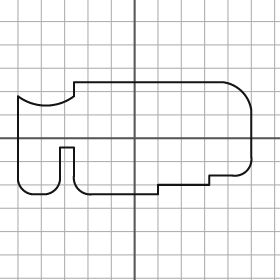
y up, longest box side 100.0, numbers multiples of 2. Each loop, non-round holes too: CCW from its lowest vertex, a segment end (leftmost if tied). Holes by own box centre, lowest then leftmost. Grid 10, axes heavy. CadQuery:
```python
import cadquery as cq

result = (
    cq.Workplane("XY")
    .moveTo(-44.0, -24.0)
    .lineTo(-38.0, -24.0)
    .threePointArc((-34.0, -22.0), (-32.0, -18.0))
    .lineTo(-32.0, -4.0)
    .lineTo(-26.0, -4.0)
    .lineTo(-26.0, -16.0)
    .threePointArc((-24.0, -22.0), (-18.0, -24.0))
    .lineTo(10.0, -24.0)
    .lineTo(10.0, -20.0)
    .lineTo(32.0, -20.0)
    .lineTo(32.0, -16.0)
    .lineTo(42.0, -16.0)
    .threePointArc((48.0, -14.0), (50.0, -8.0))
    .lineTo(50.0, 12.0)
    .threePointArc((46.0, 20.0), (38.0, 24.0))
    .lineTo(-26.0, 24.0)
    .lineTo(-26.0, 18.0)
    .threePointArc((-38.0, 14.0), (-50.0, 18.0))
    .lineTo(-50.0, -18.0)
    .threePointArc((-48.0, -22.0), (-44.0, -24.0))
    .close()
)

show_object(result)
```